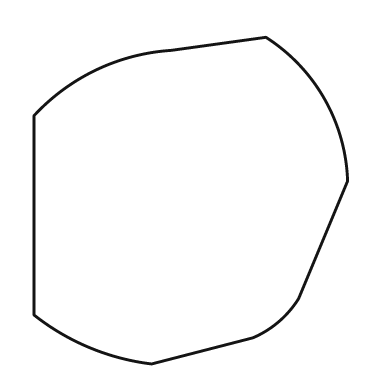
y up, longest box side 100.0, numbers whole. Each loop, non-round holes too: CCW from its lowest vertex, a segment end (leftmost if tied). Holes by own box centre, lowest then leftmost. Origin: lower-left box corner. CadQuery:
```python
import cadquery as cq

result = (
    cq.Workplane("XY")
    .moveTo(36.0, 0.0)
    .lineTo(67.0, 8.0)
    .threePointArc((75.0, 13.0), (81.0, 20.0))
    .lineTo(96.0, 56.0)
    .threePointArc((89.0, 81.0), (71.0, 100.0))
    .lineTo(42.0, 96.0)
    .threePointArc((19.0, 90.0), (0.0, 76.0))
    .lineTo(0.0, 15.0)
    .threePointArc((17.0, 5.0), (36.0, 0.0))
    .close()
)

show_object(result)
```